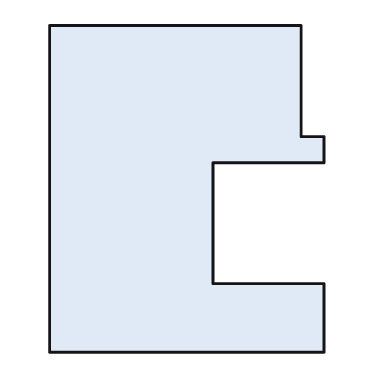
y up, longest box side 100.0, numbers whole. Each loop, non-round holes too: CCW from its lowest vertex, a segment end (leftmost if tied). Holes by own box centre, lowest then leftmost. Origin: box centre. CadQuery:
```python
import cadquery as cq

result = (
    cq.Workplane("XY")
    .moveTo(-42.0, -50.0)
    .lineTo(42.0, -50.0)
    .lineTo(42.0, -29.0)
    .lineTo(8.0, -29.0)
    .lineTo(8.0, 8.0)
    .lineTo(42.0, 8.0)
    .lineTo(42.0, 16.0)
    .lineTo(35.0, 16.0)
    .lineTo(35.0, 50.0)
    .lineTo(-42.0, 50.0)
    .close()
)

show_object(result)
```